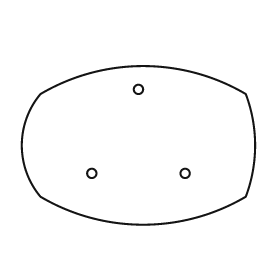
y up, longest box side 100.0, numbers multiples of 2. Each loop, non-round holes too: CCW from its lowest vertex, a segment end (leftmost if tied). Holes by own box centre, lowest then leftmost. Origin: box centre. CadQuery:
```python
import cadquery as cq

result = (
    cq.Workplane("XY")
    .moveTo(-42.0, -22.0)
    .threePointArc((2.0, -34.0), (46.0, -22.0))
    .threePointArc((50.0, 0.0), (46.0, 22.0))
    .threePointArc((2.0, 34.0), (-42.0, 22.0))
    .threePointArc((-50.0, 0.0), (-42.0, -22.0))
    .close()
    .moveTo(-20.0, -12.0)
    .circle(2.0)
    .moveTo(20.0, -12.0)
    .circle(2.0)
    .moveTo(0.0, 24.0)
    .circle(2.0)
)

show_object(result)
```